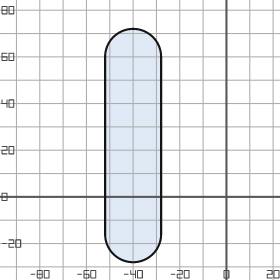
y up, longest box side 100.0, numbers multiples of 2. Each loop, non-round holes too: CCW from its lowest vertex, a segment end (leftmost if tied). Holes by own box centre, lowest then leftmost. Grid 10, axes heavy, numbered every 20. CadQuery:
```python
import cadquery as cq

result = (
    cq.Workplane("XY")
    .moveTo(-52.0, -16.0)
    .threePointArc((-40.0, -28.0), (-28.0, -16.0))
    .lineTo(-28.0, 60.0)
    .threePointArc((-40.0, 72.0), (-52.0, 60.0))
    .close()
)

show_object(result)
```